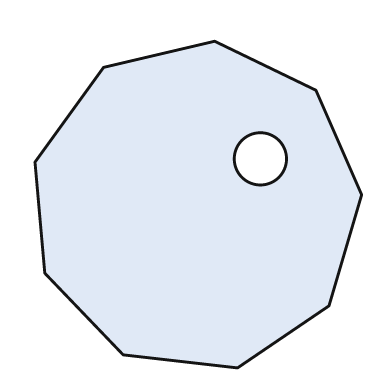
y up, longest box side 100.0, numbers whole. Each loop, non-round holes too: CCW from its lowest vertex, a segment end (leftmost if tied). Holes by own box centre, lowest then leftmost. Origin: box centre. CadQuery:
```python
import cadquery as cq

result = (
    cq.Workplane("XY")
    .moveTo(12.0, -50.0)
    .lineTo(40.0, -31.0)
    .lineTo(50.0, 3.0)
    .lineTo(36.0, 35.0)
    .lineTo(5.0, 50.0)
    .lineTo(-29.0, 42.0)
    .lineTo(-50.0, 13.0)
    .lineTo(-47.0, -21.0)
    .lineTo(-23.0, -46.0)
    .close()
    .moveTo(19.0, 14.0)
    .circle(8.0)
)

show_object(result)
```